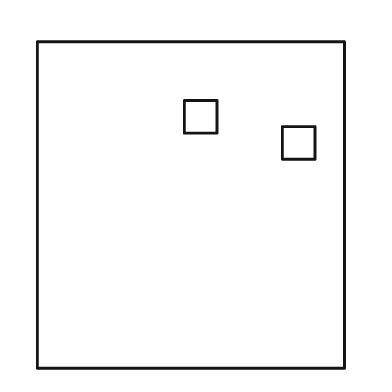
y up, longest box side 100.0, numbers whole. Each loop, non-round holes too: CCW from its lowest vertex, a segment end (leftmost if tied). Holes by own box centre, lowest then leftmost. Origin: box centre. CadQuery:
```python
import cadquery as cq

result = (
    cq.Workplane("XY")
    .moveTo(-47.0, -50.0)
    .lineTo(47.0, -50.0)
    .lineTo(47.0, 50.0)
    .lineTo(-47.0, 50.0)
    .close()
    .moveTo(28.0, 14.0)
    .lineTo(38.0, 14.0)
    .lineTo(38.0, 24.0)
    .lineTo(28.0, 24.0)
    .close()
    .moveTo(-2.0, 22.0)
    .lineTo(8.0, 22.0)
    .lineTo(8.0, 32.0)
    .lineTo(-2.0, 32.0)
    .close()
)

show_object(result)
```